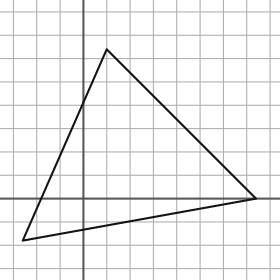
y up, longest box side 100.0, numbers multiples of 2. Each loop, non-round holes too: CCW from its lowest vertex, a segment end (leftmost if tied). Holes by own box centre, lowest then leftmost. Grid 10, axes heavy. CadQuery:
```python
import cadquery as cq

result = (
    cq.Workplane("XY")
    .moveTo(-26.0, -18.0)
    .lineTo(74.0, 0.0)
    .lineTo(10.0, 64.0)
    .close()
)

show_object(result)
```